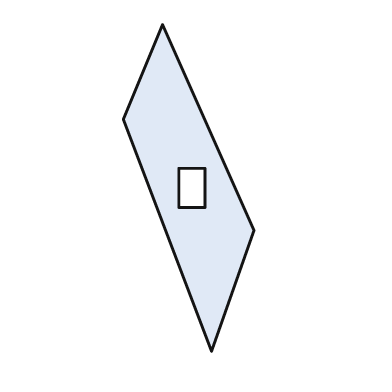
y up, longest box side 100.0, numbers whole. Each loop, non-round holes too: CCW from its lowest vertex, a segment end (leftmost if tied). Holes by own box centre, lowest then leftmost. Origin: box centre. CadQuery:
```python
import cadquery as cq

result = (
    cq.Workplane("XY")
    .moveTo(7.0, -50.0)
    .lineTo(20.0, -13.0)
    .lineTo(-8.0, 50.0)
    .lineTo(-20.0, 21.0)
    .close()
    .moveTo(-3.0, -6.0)
    .lineTo(5.0, -6.0)
    .lineTo(5.0, 6.0)
    .lineTo(-3.0, 6.0)
    .close()
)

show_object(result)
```